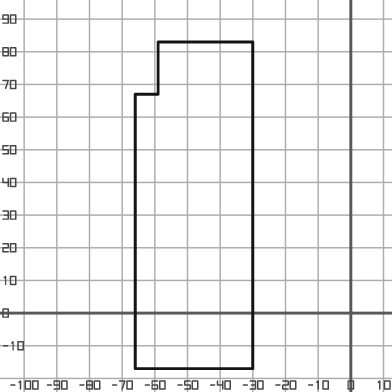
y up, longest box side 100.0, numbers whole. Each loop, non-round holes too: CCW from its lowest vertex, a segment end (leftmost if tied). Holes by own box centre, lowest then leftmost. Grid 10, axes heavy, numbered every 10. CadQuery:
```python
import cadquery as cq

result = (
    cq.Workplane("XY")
    .moveTo(-66.0, -17.0)
    .lineTo(-30.0, -17.0)
    .lineTo(-30.0, 83.0)
    .lineTo(-59.0, 83.0)
    .lineTo(-59.0, 67.0)
    .lineTo(-66.0, 67.0)
    .close()
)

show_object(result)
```